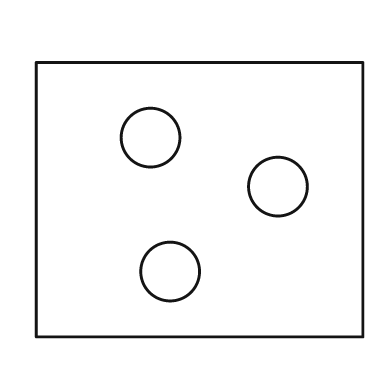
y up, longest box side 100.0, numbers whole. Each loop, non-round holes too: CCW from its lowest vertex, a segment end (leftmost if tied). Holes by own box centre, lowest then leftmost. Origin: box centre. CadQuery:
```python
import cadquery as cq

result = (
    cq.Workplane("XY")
    .moveTo(-50.0, -42.0)
    .lineTo(50.0, -42.0)
    .lineTo(50.0, 42.0)
    .lineTo(-50.0, 42.0)
    .close()
    .moveTo(-9.0, -22.0)
    .circle(9.0)
    .moveTo(24.0, 4.0)
    .circle(9.0)
    .moveTo(-15.0, 19.0)
    .circle(9.0)
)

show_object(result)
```